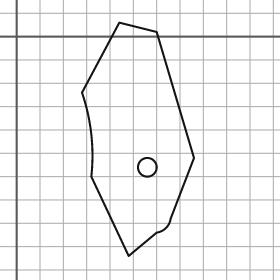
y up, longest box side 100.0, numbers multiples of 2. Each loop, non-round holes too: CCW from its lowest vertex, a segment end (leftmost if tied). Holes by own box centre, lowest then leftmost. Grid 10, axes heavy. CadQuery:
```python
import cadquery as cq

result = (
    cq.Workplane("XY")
    .moveTo(48.0, -94.0)
    .lineTo(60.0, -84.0)
    .threePointArc((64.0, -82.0), (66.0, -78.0))
    .lineTo(76.0, -52.0)
    .lineTo(60.0, 2.0)
    .lineTo(44.0, 6.0)
    .lineTo(28.0, -24.0)
    .threePointArc((32.0, -42.0), (32.0, -60.0))
    .close()
    .moveTo(56.0, -56.0)
    .circle(4.0)
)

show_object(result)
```